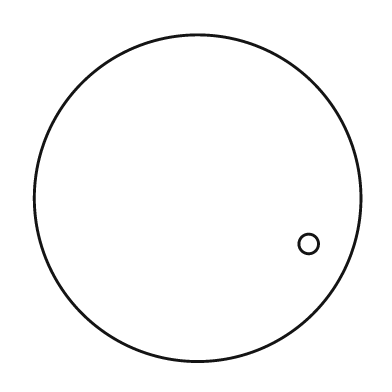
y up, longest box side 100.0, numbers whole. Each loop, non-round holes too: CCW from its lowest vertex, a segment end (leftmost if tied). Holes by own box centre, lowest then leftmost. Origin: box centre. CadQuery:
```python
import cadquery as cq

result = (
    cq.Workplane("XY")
    .moveTo(0.0, 0.0)
    .circle(50.0)
    .moveTo(34.0, -14.0)
    .circle(3.0)
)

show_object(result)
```